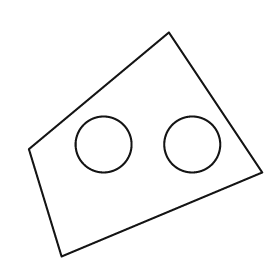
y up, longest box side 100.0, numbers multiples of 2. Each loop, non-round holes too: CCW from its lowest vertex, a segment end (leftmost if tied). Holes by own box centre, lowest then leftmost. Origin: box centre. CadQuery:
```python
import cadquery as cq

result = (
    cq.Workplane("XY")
    .moveTo(-36.0, -48.0)
    .lineTo(50.0, -12.0)
    .lineTo(10.0, 48.0)
    .lineTo(-50.0, -2.0)
    .close()
    .moveTo(-18.0, 0.0)
    .circle(12.0)
    .moveTo(20.0, 0.0)
    .circle(12.0)
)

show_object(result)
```